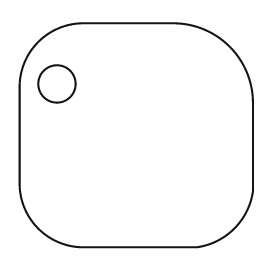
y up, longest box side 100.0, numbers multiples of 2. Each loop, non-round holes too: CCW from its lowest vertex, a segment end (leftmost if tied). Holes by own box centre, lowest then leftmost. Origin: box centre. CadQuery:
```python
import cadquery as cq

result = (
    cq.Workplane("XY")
    .moveTo(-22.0, -48.0)
    .lineTo(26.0, -48.0)
    .threePointArc((42.0, -40.0), (50.0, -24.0))
    .lineTo(50.0, 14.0)
    .threePointArc((40.0, 38.0), (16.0, 48.0))
    .lineTo(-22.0, 48.0)
    .threePointArc((-42.0, 40.0), (-50.0, 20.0))
    .lineTo(-50.0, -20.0)
    .threePointArc((-42.0, -40.0), (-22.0, -48.0))
    .close()
    .moveTo(-34.0, 22.0)
    .circle(8.0)
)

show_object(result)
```